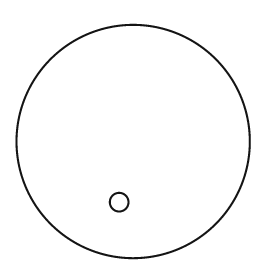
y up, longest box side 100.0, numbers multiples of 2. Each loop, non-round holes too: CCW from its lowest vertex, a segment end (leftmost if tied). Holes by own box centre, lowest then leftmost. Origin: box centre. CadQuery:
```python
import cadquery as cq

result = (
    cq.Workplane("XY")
    .moveTo(0.0, 0.0)
    .circle(50.0)
    .moveTo(-6.0, -26.0)
    .circle(4.0)
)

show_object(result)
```